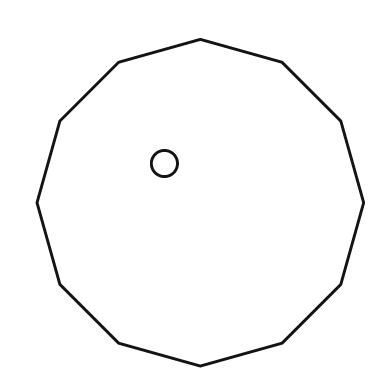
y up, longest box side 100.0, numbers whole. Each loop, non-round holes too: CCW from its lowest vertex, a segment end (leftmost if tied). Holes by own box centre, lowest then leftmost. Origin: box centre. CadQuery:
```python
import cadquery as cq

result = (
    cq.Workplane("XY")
    .moveTo(0.0, -50.0)
    .lineTo(25.0, -43.0)
    .lineTo(43.0, -25.0)
    .lineTo(50.0, 0.0)
    .lineTo(43.0, 25.0)
    .lineTo(25.0, 43.0)
    .lineTo(0.0, 50.0)
    .lineTo(-25.0, 43.0)
    .lineTo(-43.0, 25.0)
    .lineTo(-50.0, 0.0)
    .lineTo(-43.0, -25.0)
    .lineTo(-25.0, -43.0)
    .close()
    .moveTo(-11.0, 12.0)
    .circle(4.0)
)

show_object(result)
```